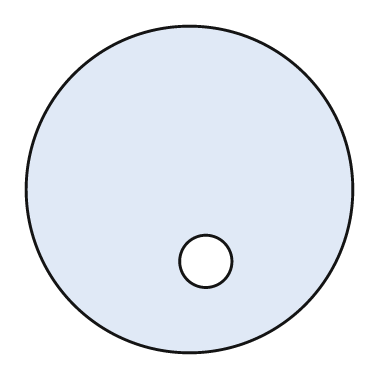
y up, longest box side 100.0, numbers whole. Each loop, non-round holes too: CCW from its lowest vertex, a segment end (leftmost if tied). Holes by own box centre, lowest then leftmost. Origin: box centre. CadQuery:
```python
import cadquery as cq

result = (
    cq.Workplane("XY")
    .moveTo(0.0, 0.0)
    .circle(50.0)
    .moveTo(5.0, -22.0)
    .circle(8.0)
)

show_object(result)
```